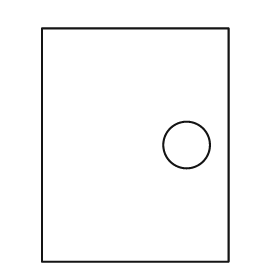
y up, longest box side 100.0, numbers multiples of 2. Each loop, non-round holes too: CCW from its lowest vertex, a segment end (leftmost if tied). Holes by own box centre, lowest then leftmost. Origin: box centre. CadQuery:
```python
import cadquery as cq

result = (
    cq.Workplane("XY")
    .moveTo(-40.0, -50.0)
    .lineTo(40.0, -50.0)
    .lineTo(40.0, 50.0)
    .lineTo(-40.0, 50.0)
    .close()
    .moveTo(22.0, 0.0)
    .circle(10.0)
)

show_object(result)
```